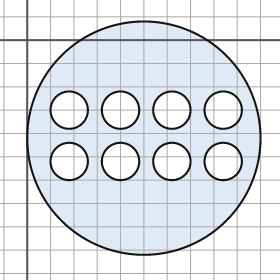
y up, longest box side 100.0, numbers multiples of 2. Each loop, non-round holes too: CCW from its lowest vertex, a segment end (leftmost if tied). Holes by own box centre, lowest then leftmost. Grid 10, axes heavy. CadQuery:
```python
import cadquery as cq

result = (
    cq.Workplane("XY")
    .moveTo(50.0, -42.0)
    .circle(50.0)
    .moveTo(18.0, -52.0)
    .circle(8.0)
    .moveTo(40.0, -52.0)
    .circle(8.0)
    .moveTo(62.0, -52.0)
    .circle(8.0)
    .moveTo(84.0, -52.0)
    .circle(8.0)
    .moveTo(18.0, -30.0)
    .circle(8.0)
    .moveTo(40.0, -30.0)
    .circle(8.0)
    .moveTo(62.0, -30.0)
    .circle(8.0)
    .moveTo(84.0, -30.0)
    .circle(8.0)
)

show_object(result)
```